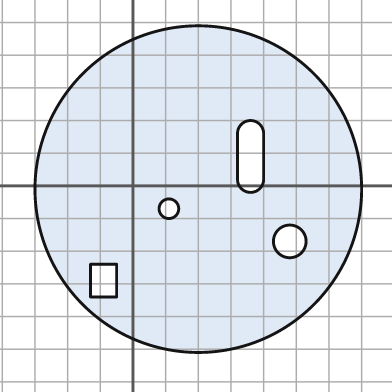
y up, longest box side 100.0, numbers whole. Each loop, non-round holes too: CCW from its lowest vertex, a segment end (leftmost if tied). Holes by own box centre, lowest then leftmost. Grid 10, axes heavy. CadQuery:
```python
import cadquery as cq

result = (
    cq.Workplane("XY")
    .moveTo(20.0, -1.0)
    .circle(50.0)
    .moveTo(-13.0, -34.0)
    .lineTo(-5.0, -34.0)
    .lineTo(-5.0, -24.0)
    .lineTo(-13.0, -24.0)
    .close()
    .moveTo(48.0, -17.0)
    .circle(5.0)
    .moveTo(11.0, -7.0)
    .circle(3.0)
    .moveTo(32.0, 2.0)
    .threePointArc((36.0, -2.0), (40.0, 2.0))
    .lineTo(40.0, 16.0)
    .threePointArc((36.0, 20.0), (32.0, 16.0))
    .close()
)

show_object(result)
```